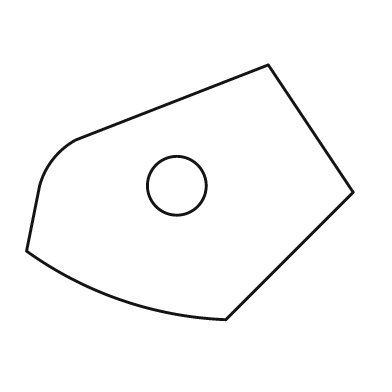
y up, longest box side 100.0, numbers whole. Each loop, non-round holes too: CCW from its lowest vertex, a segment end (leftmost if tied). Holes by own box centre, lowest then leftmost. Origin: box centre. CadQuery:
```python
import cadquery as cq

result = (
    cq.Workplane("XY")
    .moveTo(11.0, -39.0)
    .lineTo(50.0, 0.0)
    .lineTo(24.0, 39.0)
    .lineTo(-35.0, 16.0)
    .threePointArc((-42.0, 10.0), (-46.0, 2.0))
    .lineTo(-50.0, -18.0)
    .threePointArc((-21.0, -33.0), (11.0, -39.0))
    .close()
    .moveTo(-4.0, 2.0)
    .circle(9.0)
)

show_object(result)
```